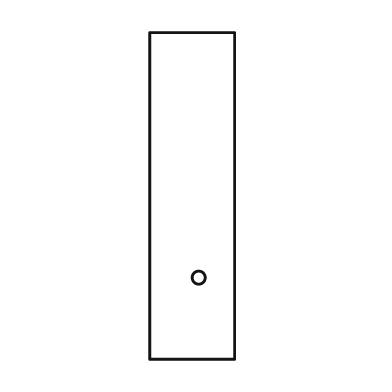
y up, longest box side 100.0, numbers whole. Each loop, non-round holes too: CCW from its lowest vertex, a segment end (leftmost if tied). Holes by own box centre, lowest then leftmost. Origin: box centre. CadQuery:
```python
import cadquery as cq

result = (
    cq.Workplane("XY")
    .moveTo(-13.0, -50.0)
    .lineTo(13.0, -50.0)
    .lineTo(13.0, 50.0)
    .lineTo(-13.0, 50.0)
    .close()
    .moveTo(2.0, -25.0)
    .circle(2.0)
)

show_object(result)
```